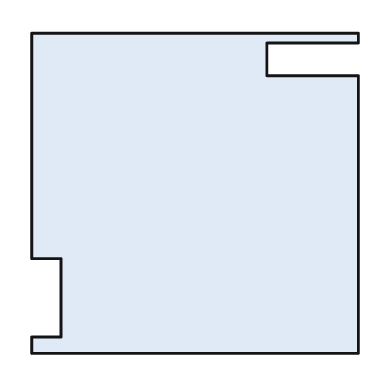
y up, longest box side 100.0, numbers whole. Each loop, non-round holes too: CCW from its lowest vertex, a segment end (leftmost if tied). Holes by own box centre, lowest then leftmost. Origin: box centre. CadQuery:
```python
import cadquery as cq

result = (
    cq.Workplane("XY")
    .moveTo(-50.0, -49.0)
    .lineTo(50.0, -49.0)
    .lineTo(50.0, 36.0)
    .lineTo(22.0, 36.0)
    .lineTo(22.0, 46.0)
    .lineTo(50.0, 46.0)
    .lineTo(50.0, 49.0)
    .lineTo(-50.0, 49.0)
    .lineTo(-50.0, -20.0)
    .lineTo(-41.0, -20.0)
    .lineTo(-41.0, -44.0)
    .lineTo(-50.0, -44.0)
    .close()
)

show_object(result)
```